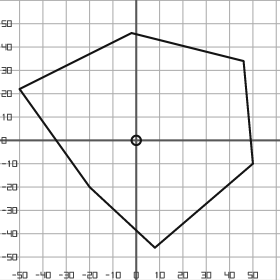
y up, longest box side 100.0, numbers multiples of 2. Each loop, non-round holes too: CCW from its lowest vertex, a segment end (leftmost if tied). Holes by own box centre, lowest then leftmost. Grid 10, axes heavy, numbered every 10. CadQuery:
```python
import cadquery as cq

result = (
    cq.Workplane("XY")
    .moveTo(8.0, -46.0)
    .lineTo(50.0, -10.0)
    .lineTo(46.0, 34.0)
    .lineTo(-2.0, 46.0)
    .lineTo(-50.0, 22.0)
    .lineTo(-20.0, -20.0)
    .close()
    .moveTo(0.0, 0.0)
    .circle(2.0)
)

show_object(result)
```